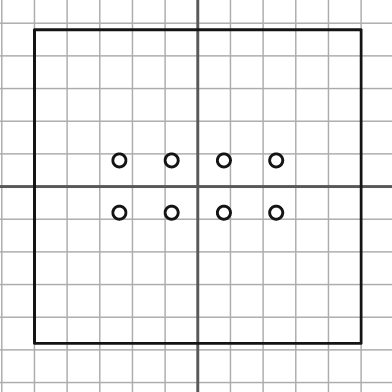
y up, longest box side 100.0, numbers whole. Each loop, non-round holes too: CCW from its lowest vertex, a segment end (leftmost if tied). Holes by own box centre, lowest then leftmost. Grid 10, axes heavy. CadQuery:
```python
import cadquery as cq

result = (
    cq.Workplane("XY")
    .moveTo(-50.0, -48.0)
    .lineTo(50.0, -48.0)
    .lineTo(50.0, 48.0)
    .lineTo(-50.0, 48.0)
    .close()
    .moveTo(-24.0, -8.0)
    .circle(2.0)
    .moveTo(-8.0, -8.0)
    .circle(2.0)
    .moveTo(8.0, -8.0)
    .circle(2.0)
    .moveTo(24.0, -8.0)
    .circle(2.0)
    .moveTo(-24.0, 8.0)
    .circle(2.0)
    .moveTo(-8.0, 8.0)
    .circle(2.0)
    .moveTo(8.0, 8.0)
    .circle(2.0)
    .moveTo(24.0, 8.0)
    .circle(2.0)
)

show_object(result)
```